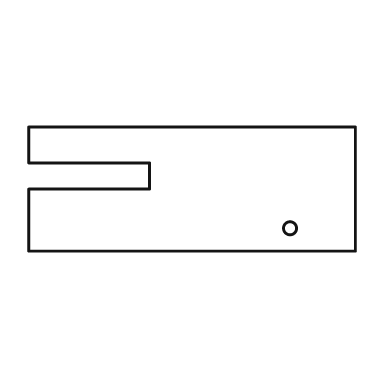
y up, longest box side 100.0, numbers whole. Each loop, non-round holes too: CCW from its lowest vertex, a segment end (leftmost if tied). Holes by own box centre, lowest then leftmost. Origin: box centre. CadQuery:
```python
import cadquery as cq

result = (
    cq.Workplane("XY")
    .moveTo(-50.0, -19.0)
    .lineTo(50.0, -19.0)
    .lineTo(50.0, 19.0)
    .lineTo(-50.0, 19.0)
    .lineTo(-50.0, 8.0)
    .lineTo(-13.0, 8.0)
    .lineTo(-13.0, 0.0)
    .lineTo(-50.0, 0.0)
    .close()
    .moveTo(30.0, -12.0)
    .circle(2.0)
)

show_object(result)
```